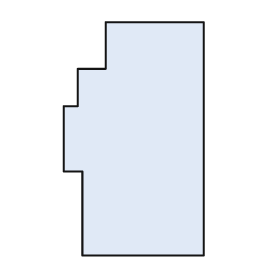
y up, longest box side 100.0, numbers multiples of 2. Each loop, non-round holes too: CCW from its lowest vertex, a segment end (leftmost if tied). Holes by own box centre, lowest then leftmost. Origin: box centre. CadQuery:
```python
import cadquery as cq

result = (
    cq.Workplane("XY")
    .moveTo(-22.0, -50.0)
    .lineTo(30.0, -50.0)
    .lineTo(30.0, 50.0)
    .lineTo(-12.0, 50.0)
    .lineTo(-12.0, 30.0)
    .lineTo(-24.0, 30.0)
    .lineTo(-24.0, 14.0)
    .lineTo(-30.0, 14.0)
    .lineTo(-30.0, -14.0)
    .lineTo(-22.0, -14.0)
    .close()
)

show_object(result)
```